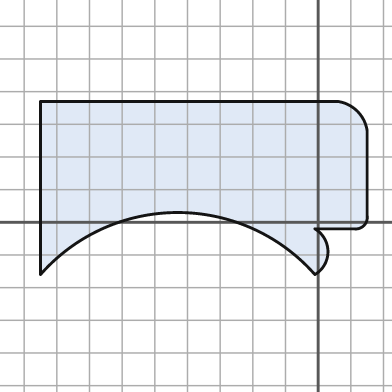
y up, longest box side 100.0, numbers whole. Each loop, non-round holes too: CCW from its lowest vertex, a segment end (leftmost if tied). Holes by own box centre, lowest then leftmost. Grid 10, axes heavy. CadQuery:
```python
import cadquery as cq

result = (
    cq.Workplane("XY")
    .moveTo(-85.0, -16.0)
    .threePointArc((-43.0, 3.0), (-1.0, -16.0))
    .threePointArc((3.0, -9.0), (-1.0, -2.0))
    .lineTo(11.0, -2.0)
    .threePointArc((14.0, -1.0), (15.0, 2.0))
    .lineTo(15.0, 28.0)
    .threePointArc((12.0, 34.0), (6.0, 37.0))
    .lineTo(-85.0, 37.0)
    .close()
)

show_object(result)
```